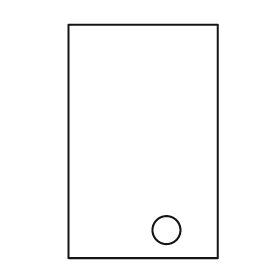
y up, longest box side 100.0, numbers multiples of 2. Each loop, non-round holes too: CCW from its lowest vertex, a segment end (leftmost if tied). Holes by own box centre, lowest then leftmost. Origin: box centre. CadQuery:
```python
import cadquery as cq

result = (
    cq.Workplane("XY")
    .moveTo(-32.0, -50.0)
    .lineTo(32.0, -50.0)
    .lineTo(32.0, 50.0)
    .lineTo(-32.0, 50.0)
    .close()
    .moveTo(10.0, -38.0)
    .circle(6.0)
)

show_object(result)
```